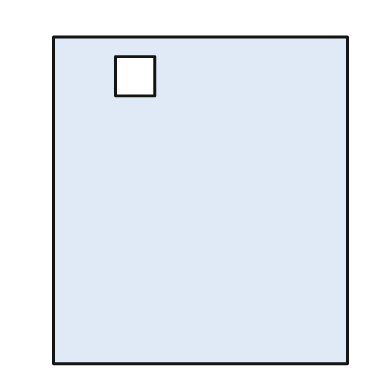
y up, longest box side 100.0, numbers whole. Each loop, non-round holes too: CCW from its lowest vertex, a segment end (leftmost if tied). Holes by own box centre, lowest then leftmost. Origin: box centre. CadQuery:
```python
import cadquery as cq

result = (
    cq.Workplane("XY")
    .moveTo(-45.0, -50.0)
    .lineTo(45.0, -50.0)
    .lineTo(45.0, 50.0)
    .lineTo(-45.0, 50.0)
    .close()
    .moveTo(-26.0, 32.0)
    .lineTo(-14.0, 32.0)
    .lineTo(-14.0, 44.0)
    .lineTo(-26.0, 44.0)
    .close()
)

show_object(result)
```